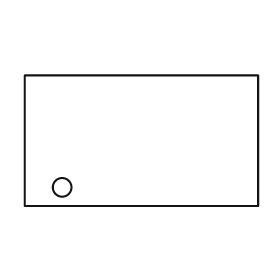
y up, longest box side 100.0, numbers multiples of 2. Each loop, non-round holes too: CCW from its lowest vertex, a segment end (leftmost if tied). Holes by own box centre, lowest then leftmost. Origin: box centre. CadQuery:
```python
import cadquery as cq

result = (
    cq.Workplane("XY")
    .moveTo(-50.0, -28.0)
    .lineTo(50.0, -28.0)
    .lineTo(50.0, 28.0)
    .lineTo(-50.0, 28.0)
    .close()
    .moveTo(-34.0, -20.0)
    .circle(4.0)
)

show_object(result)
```